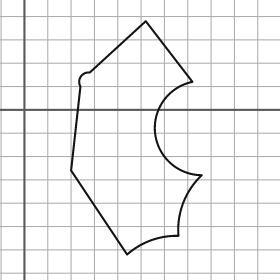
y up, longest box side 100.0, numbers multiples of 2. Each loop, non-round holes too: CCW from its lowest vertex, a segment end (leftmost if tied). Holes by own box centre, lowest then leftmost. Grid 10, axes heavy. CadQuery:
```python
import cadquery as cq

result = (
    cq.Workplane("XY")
    .moveTo(44.0, -62.0)
    .threePointArc((54.0, -56.0), (66.0, -54.0))
    .threePointArc((68.0, -40.0), (76.0, -28.0))
    .threePointArc((56.0, -10.0), (72.0, 12.0))
    .lineTo(52.0, 38.0)
    .lineTo(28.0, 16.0)
    .threePointArc((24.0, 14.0), (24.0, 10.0))
    .lineTo(20.0, -26.0)
    .close()
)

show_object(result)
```